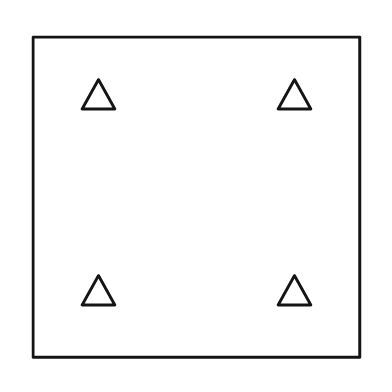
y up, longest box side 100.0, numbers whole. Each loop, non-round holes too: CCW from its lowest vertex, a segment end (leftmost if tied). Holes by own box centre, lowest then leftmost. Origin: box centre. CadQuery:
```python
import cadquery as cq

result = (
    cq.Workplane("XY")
    .moveTo(-50.0, -49.0)
    .lineTo(50.0, -49.0)
    .lineTo(50.0, 49.0)
    .lineTo(-50.0, 49.0)
    .close()
    .moveTo(-35.0, -33.0)
    .lineTo(-25.0, -33.0)
    .lineTo(-30.0, -24.0)
    .close()
    .moveTo(25.0, -33.0)
    .lineTo(35.0, -33.0)
    .lineTo(30.0, -24.0)
    .close()
    .moveTo(-35.0, 27.0)
    .lineTo(-25.0, 27.0)
    .lineTo(-30.0, 36.0)
    .close()
    .moveTo(25.0, 27.0)
    .lineTo(35.0, 27.0)
    .lineTo(30.0, 36.0)
    .close()
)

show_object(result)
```